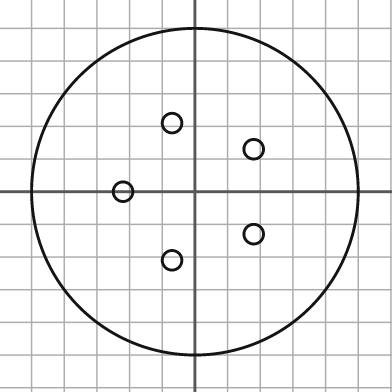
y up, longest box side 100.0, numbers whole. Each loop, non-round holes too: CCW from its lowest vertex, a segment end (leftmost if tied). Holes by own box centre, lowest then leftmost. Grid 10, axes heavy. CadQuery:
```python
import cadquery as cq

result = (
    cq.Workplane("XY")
    .moveTo(0.0, 0.0)
    .circle(50.0)
    .moveTo(-7.0, -21.0)
    .circle(3.0)
    .moveTo(18.0, -13.0)
    .circle(3.0)
    .moveTo(-22.0, 0.0)
    .circle(3.0)
    .moveTo(18.0, 13.0)
    .circle(3.0)
    .moveTo(-7.0, 21.0)
    .circle(3.0)
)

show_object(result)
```